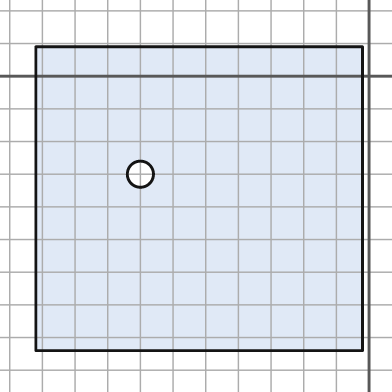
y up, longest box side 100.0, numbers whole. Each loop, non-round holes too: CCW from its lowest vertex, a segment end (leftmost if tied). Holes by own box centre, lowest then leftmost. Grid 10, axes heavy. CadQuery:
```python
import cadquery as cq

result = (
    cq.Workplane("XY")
    .moveTo(-102.0, -84.0)
    .lineTo(-2.0, -84.0)
    .lineTo(-2.0, 9.0)
    .lineTo(-102.0, 9.0)
    .close()
    .moveTo(-70.0, -30.0)
    .circle(4.0)
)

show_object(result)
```